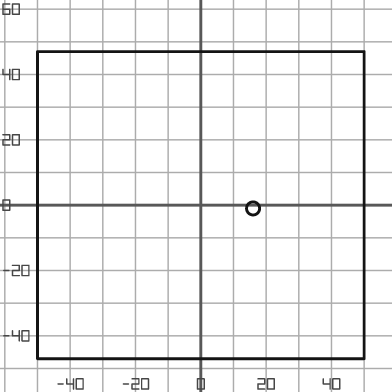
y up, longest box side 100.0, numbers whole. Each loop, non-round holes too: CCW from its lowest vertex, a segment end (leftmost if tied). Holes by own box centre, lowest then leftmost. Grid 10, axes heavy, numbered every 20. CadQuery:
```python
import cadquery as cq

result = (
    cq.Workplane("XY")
    .moveTo(-50.0, -47.0)
    .lineTo(50.0, -47.0)
    .lineTo(50.0, 47.0)
    .lineTo(-50.0, 47.0)
    .close()
    .moveTo(16.0, -1.0)
    .circle(2.0)
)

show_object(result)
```